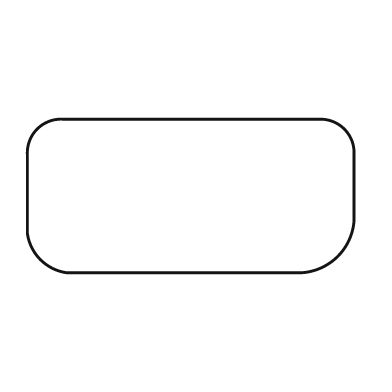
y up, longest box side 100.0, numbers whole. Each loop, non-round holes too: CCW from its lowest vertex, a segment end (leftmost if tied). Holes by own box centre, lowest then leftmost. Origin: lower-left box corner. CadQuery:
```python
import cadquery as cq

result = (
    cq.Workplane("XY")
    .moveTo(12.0, 0.0)
    .lineTo(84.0, 0.0)
    .threePointArc((95.0, 5.0), (100.0, 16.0))
    .lineTo(100.0, 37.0)
    .threePointArc((97.0, 44.0), (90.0, 47.0))
    .lineTo(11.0, 47.0)
    .threePointArc((3.0, 44.0), (0.0, 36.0))
    .lineTo(0.0, 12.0)
    .threePointArc((4.0, 4.0), (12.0, 0.0))
    .close()
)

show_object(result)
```